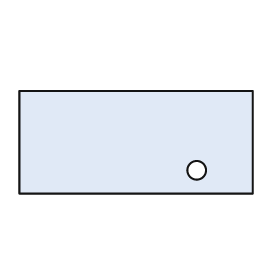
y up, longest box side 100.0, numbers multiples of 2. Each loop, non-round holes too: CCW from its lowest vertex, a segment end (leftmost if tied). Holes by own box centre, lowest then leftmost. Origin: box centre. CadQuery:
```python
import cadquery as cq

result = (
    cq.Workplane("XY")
    .moveTo(-50.0, -22.0)
    .lineTo(50.0, -22.0)
    .lineTo(50.0, 22.0)
    .lineTo(-50.0, 22.0)
    .close()
    .moveTo(26.0, -12.0)
    .circle(4.0)
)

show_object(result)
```